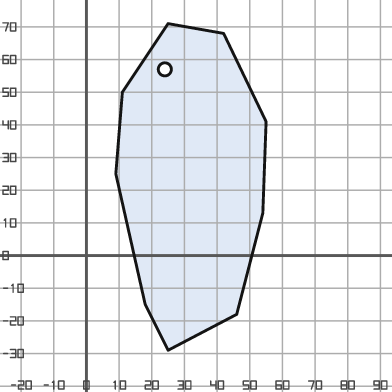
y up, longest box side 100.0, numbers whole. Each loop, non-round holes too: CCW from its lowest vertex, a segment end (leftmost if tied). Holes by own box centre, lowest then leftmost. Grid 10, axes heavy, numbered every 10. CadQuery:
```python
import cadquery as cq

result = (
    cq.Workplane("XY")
    .moveTo(25.0, -29.0)
    .lineTo(46.0, -18.0)
    .lineTo(54.0, 13.0)
    .lineTo(55.0, 41.0)
    .lineTo(42.0, 68.0)
    .lineTo(25.0, 71.0)
    .lineTo(11.0, 50.0)
    .lineTo(9.0, 25.0)
    .lineTo(18.0, -15.0)
    .close()
    .moveTo(24.0, 57.0)
    .circle(2.0)
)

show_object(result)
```